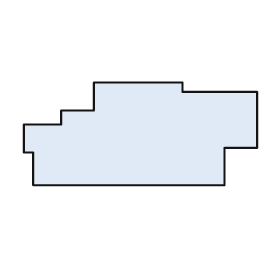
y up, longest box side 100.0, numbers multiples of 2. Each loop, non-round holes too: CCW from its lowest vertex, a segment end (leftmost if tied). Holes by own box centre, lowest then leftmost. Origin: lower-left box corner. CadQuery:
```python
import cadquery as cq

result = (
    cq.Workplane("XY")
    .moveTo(4.0, 0.0)
    .lineTo(86.0, 0.0)
    .lineTo(86.0, 16.0)
    .lineTo(100.0, 16.0)
    .lineTo(100.0, 40.0)
    .lineTo(68.0, 40.0)
    .lineTo(68.0, 44.0)
    .lineTo(30.0, 44.0)
    .lineTo(30.0, 32.0)
    .lineTo(16.0, 32.0)
    .lineTo(16.0, 26.0)
    .lineTo(0.0, 26.0)
    .lineTo(0.0, 14.0)
    .lineTo(4.0, 14.0)
    .close()
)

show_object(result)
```